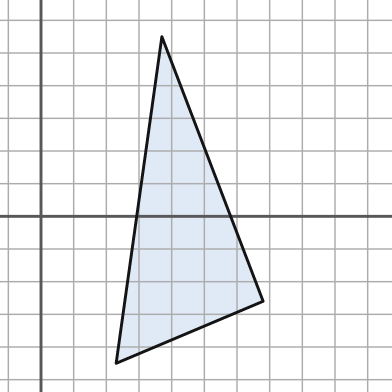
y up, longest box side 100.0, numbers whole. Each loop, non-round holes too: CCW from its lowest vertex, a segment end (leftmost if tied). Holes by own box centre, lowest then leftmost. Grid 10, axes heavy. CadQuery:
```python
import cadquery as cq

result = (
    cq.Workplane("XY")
    .moveTo(23.0, -45.0)
    .lineTo(68.0, -26.0)
    .lineTo(37.0, 55.0)
    .close()
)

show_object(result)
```